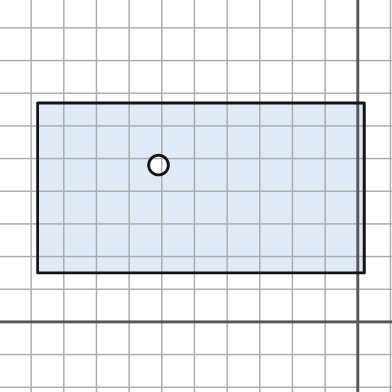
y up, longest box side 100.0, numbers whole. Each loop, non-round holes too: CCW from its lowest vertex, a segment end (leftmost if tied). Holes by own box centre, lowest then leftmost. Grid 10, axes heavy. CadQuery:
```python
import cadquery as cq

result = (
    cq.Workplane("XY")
    .moveTo(-98.0, 15.0)
    .lineTo(2.0, 15.0)
    .lineTo(2.0, 67.0)
    .lineTo(-98.0, 67.0)
    .close()
    .moveTo(-61.0, 48.0)
    .circle(3.0)
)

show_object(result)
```